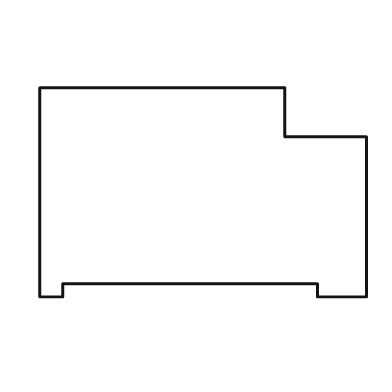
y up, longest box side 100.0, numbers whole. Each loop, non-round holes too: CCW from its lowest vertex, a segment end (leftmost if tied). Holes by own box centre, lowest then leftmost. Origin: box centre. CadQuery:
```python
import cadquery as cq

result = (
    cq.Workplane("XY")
    .moveTo(-50.0, -32.0)
    .lineTo(-43.0, -32.0)
    .lineTo(-43.0, -28.0)
    .lineTo(35.0, -28.0)
    .lineTo(35.0, -32.0)
    .lineTo(50.0, -32.0)
    .lineTo(50.0, 17.0)
    .lineTo(25.0, 17.0)
    .lineTo(25.0, 32.0)
    .lineTo(-50.0, 32.0)
    .close()
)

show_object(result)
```